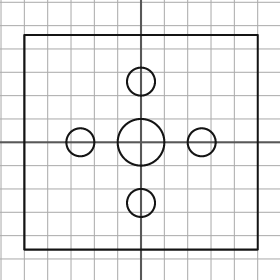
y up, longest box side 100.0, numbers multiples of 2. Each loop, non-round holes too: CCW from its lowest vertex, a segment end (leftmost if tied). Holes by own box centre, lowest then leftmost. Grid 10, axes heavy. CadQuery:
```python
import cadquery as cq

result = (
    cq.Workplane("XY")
    .moveTo(-50.0, -46.0)
    .lineTo(50.0, -46.0)
    .lineTo(50.0, 46.0)
    .lineTo(-50.0, 46.0)
    .close()
    .moveTo(0.0, -26.0)
    .circle(6.0)
    .moveTo(-26.0, 0.0)
    .circle(6.0)
    .moveTo(0.0, 0.0)
    .circle(10.0)
    .moveTo(26.0, 0.0)
    .circle(6.0)
    .moveTo(0.0, 26.0)
    .circle(6.0)
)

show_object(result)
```